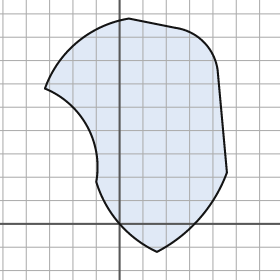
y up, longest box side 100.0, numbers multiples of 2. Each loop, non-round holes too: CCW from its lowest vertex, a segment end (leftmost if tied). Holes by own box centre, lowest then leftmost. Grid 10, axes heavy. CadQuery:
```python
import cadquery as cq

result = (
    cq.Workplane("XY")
    .moveTo(16.0, -12.0)
    .threePointArc((34.0, 2.0), (46.0, 22.0))
    .lineTo(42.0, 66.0)
    .threePointArc((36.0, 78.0), (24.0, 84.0))
    .lineTo(4.0, 88.0)
    .threePointArc((-18.0, 78.0), (-32.0, 58.0))
    .threePointArc((-14.0, 42.0), (-10.0, 18.0))
    .threePointArc((0.0, 0.0), (16.0, -12.0))
    .close()
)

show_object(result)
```